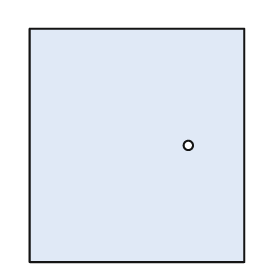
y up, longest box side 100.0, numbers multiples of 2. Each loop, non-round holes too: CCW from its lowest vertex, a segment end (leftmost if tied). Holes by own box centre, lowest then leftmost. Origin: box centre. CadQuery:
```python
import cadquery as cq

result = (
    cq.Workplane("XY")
    .moveTo(-46.0, -50.0)
    .lineTo(46.0, -50.0)
    .lineTo(46.0, 50.0)
    .lineTo(-46.0, 50.0)
    .close()
    .moveTo(22.0, 0.0)
    .circle(2.0)
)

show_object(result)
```